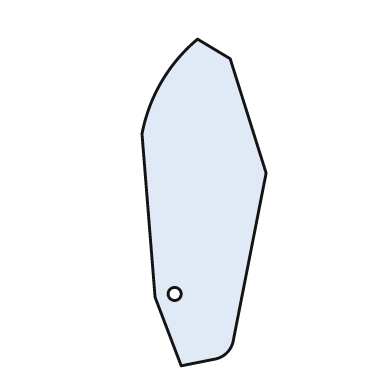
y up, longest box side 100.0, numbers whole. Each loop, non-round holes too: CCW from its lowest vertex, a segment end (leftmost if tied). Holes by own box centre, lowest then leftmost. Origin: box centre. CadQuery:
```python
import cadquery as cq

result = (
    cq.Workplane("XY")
    .moveTo(-7.0, -50.0)
    .lineTo(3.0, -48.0)
    .threePointArc((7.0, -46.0), (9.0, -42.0))
    .lineTo(19.0, 9.0)
    .lineTo(8.0, 44.0)
    .lineTo(-2.0, 50.0)
    .threePointArc((-13.0, 37.0), (-19.0, 21.0))
    .lineTo(-15.0, -29.0)
    .close()
    .moveTo(-9.0, -28.0)
    .circle(2.0)
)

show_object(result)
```